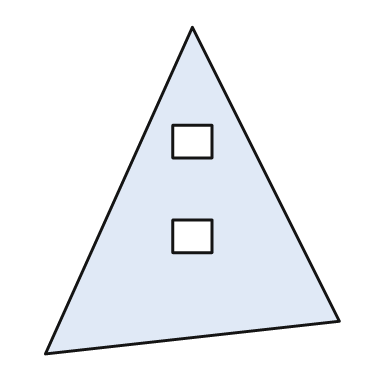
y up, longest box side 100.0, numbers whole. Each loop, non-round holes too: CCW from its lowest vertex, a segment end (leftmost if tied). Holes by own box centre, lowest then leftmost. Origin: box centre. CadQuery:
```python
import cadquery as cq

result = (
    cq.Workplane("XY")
    .moveTo(-45.0, -50.0)
    .lineTo(45.0, -40.0)
    .lineTo(0.0, 50.0)
    .close()
    .moveTo(-6.0, -19.0)
    .lineTo(6.0, -19.0)
    .lineTo(6.0, -9.0)
    .lineTo(-6.0, -9.0)
    .close()
    .moveTo(-6.0, 10.0)
    .lineTo(6.0, 10.0)
    .lineTo(6.0, 20.0)
    .lineTo(-6.0, 20.0)
    .close()
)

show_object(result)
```